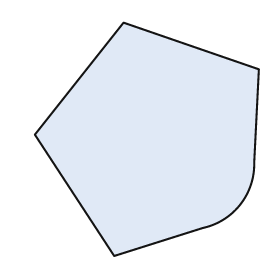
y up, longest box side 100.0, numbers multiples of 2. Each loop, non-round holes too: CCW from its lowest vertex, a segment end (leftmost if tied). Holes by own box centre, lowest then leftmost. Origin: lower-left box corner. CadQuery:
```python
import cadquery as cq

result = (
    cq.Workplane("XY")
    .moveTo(34.0, 0.0)
    .lineTo(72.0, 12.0)
    .threePointArc((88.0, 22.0), (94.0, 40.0))
    .lineTo(96.0, 80.0)
    .lineTo(38.0, 100.0)
    .lineTo(0.0, 52.0)
    .close()
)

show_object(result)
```